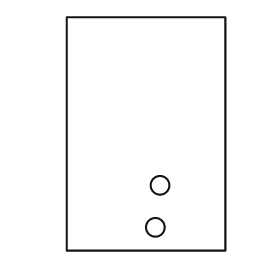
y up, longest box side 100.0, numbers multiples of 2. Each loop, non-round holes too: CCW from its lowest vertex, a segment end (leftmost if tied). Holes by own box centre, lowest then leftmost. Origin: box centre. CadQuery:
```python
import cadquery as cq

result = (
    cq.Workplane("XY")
    .moveTo(-34.0, -50.0)
    .lineTo(34.0, -50.0)
    .lineTo(34.0, 50.0)
    .lineTo(-34.0, 50.0)
    .close()
    .moveTo(4.0, -40.0)
    .circle(4.0)
    .moveTo(6.0, -22.0)
    .circle(4.0)
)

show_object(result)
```